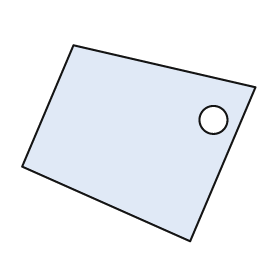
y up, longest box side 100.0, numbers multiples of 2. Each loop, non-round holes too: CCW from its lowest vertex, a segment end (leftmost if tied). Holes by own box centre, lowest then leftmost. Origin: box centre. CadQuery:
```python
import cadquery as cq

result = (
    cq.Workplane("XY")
    .moveTo(22.0, -42.0)
    .lineTo(50.0, 24.0)
    .lineTo(-28.0, 42.0)
    .lineTo(-50.0, -10.0)
    .close()
    .moveTo(32.0, 10.0)
    .circle(6.0)
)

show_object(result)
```